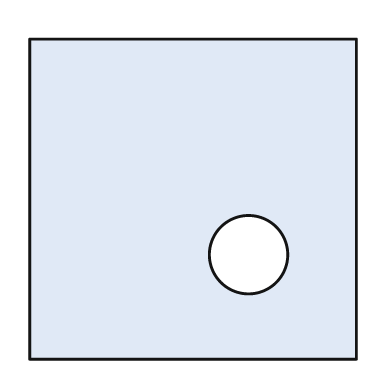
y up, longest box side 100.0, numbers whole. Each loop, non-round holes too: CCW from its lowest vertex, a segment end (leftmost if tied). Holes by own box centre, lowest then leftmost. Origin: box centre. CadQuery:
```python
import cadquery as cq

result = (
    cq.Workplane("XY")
    .moveTo(-50.0, -49.0)
    .lineTo(50.0, -49.0)
    .lineTo(50.0, 49.0)
    .lineTo(-50.0, 49.0)
    .close()
    .moveTo(17.0, -17.0)
    .circle(12.0)
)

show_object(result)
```